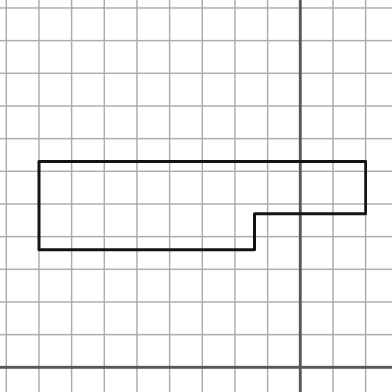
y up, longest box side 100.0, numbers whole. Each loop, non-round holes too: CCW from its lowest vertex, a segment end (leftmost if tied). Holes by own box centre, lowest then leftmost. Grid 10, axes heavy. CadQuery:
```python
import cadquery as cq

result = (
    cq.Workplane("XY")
    .moveTo(-80.0, 36.0)
    .lineTo(-14.0, 36.0)
    .lineTo(-14.0, 47.0)
    .lineTo(20.0, 47.0)
    .lineTo(20.0, 63.0)
    .lineTo(-80.0, 63.0)
    .close()
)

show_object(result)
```